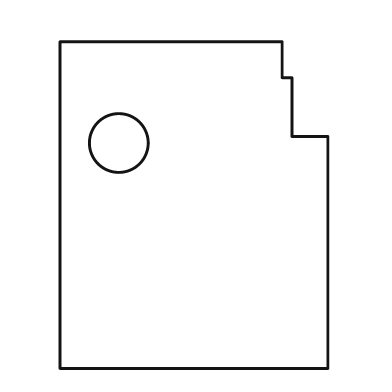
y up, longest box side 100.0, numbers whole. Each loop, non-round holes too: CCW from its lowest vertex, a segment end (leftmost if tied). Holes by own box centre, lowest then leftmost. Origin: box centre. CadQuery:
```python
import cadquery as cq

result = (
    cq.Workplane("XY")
    .moveTo(-41.0, -50.0)
    .lineTo(41.0, -50.0)
    .lineTo(41.0, 21.0)
    .lineTo(30.0, 21.0)
    .lineTo(30.0, 39.0)
    .lineTo(27.0, 39.0)
    .lineTo(27.0, 50.0)
    .lineTo(-41.0, 50.0)
    .close()
    .moveTo(-23.0, 19.0)
    .circle(9.0)
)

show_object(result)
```